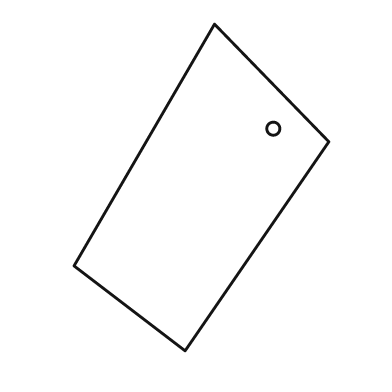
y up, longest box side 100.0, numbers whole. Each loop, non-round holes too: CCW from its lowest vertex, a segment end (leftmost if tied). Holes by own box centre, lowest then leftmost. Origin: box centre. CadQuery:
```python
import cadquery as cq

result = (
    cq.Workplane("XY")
    .moveTo(-5.0, -50.0)
    .lineTo(39.0, 14.0)
    .lineTo(4.0, 50.0)
    .lineTo(-39.0, -24.0)
    .close()
    .moveTo(22.0, 18.0)
    .circle(2.0)
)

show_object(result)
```